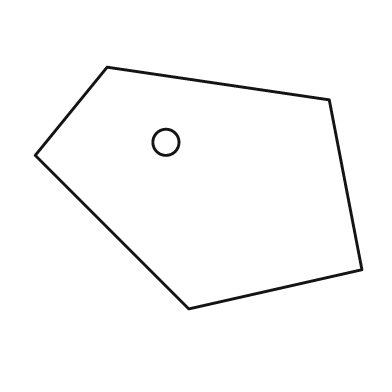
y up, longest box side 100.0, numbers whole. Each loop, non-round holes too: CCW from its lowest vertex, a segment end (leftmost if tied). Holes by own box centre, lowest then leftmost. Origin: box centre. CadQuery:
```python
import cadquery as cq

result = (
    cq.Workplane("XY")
    .moveTo(-3.0, -37.0)
    .lineTo(50.0, -25.0)
    .lineTo(40.0, 27.0)
    .lineTo(-28.0, 37.0)
    .lineTo(-50.0, 10.0)
    .close()
    .moveTo(-10.0, 14.0)
    .circle(4.0)
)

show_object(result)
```